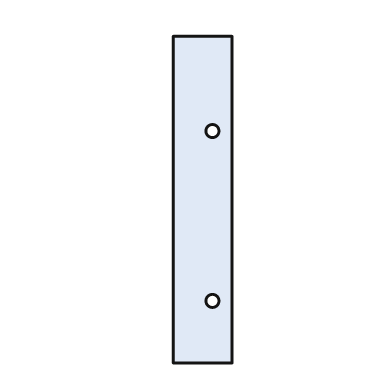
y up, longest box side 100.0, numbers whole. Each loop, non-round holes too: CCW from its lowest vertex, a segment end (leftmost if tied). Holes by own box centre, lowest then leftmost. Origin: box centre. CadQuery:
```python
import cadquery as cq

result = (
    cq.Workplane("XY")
    .moveTo(-9.0, -50.0)
    .lineTo(9.0, -50.0)
    .lineTo(9.0, 50.0)
    .lineTo(-9.0, 50.0)
    .close()
    .moveTo(3.0, -31.0)
    .circle(2.0)
    .moveTo(3.0, 21.0)
    .circle(2.0)
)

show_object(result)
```